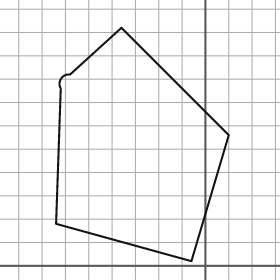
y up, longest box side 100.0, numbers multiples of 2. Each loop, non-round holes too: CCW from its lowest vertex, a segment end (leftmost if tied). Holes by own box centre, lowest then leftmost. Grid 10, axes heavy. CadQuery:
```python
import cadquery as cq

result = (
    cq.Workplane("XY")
    .moveTo(-6.0, 2.0)
    .lineTo(10.0, 56.0)
    .lineTo(-36.0, 102.0)
    .lineTo(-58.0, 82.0)
    .threePointArc((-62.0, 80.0), (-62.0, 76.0))
    .lineTo(-64.0, 18.0)
    .close()
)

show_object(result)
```